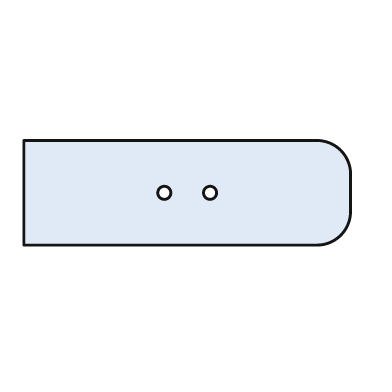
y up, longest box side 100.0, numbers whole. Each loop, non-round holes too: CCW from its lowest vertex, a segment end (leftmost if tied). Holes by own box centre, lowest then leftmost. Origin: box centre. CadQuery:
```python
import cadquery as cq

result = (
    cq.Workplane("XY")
    .moveTo(-50.0, -16.0)
    .lineTo(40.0, -16.0)
    .threePointArc((47.0, -13.0), (50.0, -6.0))
    .lineTo(50.0, 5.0)
    .threePointArc((47.0, 13.0), (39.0, 16.0))
    .lineTo(-50.0, 16.0)
    .close()
    .moveTo(-7.0, 0.0)
    .circle(2.0)
    .moveTo(7.0, 0.0)
    .circle(2.0)
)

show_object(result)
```